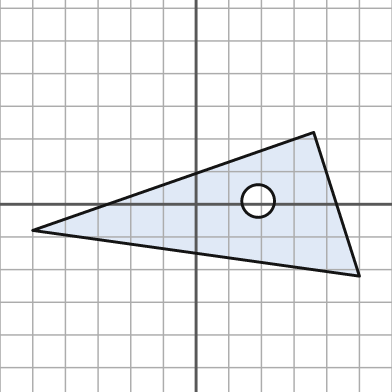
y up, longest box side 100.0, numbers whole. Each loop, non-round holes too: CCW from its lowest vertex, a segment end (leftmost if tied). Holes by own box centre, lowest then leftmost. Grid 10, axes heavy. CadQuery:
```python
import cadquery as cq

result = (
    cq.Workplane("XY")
    .moveTo(50.0, -22.0)
    .lineTo(36.0, 22.0)
    .lineTo(-50.0, -8.0)
    .close()
    .moveTo(19.0, 1.0)
    .circle(5.0)
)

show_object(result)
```